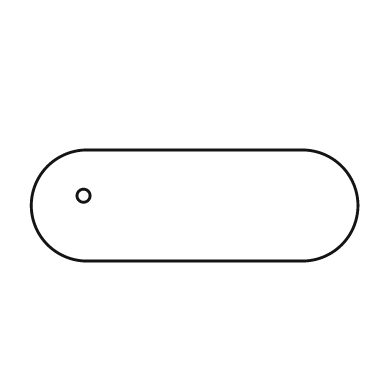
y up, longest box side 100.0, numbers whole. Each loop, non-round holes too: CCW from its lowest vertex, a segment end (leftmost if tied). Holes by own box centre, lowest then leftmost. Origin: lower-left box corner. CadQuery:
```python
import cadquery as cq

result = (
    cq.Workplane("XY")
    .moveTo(17.0, 0.0)
    .lineTo(83.0, 0.0)
    .threePointArc((100.0, 17.0), (83.0, 34.0))
    .lineTo(17.0, 34.0)
    .threePointArc((0.0, 17.0), (17.0, 0.0))
    .close()
    .moveTo(16.0, 20.0)
    .circle(2.0)
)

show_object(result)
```